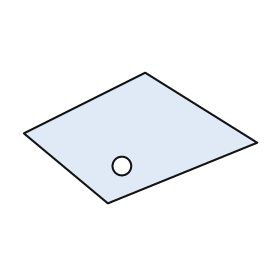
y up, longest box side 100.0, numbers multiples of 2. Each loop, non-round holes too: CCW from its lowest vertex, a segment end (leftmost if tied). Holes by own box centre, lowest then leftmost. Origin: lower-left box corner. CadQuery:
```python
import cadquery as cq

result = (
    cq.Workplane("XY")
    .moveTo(36.0, 0.0)
    .lineTo(100.0, 26.0)
    .lineTo(52.0, 56.0)
    .lineTo(0.0, 30.0)
    .close()
    .moveTo(42.0, 16.0)
    .circle(4.0)
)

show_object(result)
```